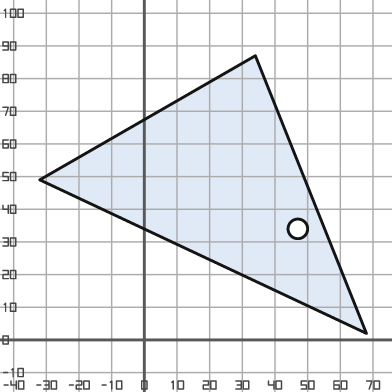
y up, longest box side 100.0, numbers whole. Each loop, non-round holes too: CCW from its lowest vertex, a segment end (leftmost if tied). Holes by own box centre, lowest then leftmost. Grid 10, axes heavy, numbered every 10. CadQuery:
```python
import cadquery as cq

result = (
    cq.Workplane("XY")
    .moveTo(68.0, 2.0)
    .lineTo(34.0, 87.0)
    .lineTo(-32.0, 49.0)
    .close()
    .moveTo(47.0, 34.0)
    .circle(3.0)
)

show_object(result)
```